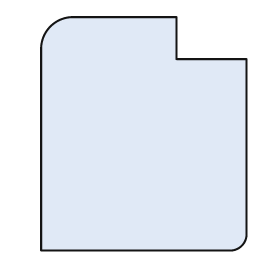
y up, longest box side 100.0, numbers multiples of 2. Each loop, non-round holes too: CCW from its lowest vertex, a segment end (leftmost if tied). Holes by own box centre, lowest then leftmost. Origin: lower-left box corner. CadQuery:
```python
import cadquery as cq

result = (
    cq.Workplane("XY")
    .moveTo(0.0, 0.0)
    .lineTo(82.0, 0.0)
    .threePointArc((86.0, 2.0), (88.0, 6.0))
    .lineTo(88.0, 82.0)
    .lineTo(58.0, 82.0)
    .lineTo(58.0, 100.0)
    .lineTo(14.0, 100.0)
    .threePointArc((4.0, 96.0), (0.0, 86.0))
    .close()
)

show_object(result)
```